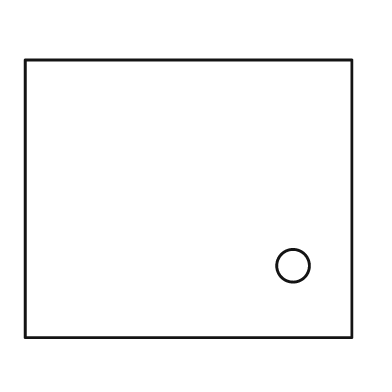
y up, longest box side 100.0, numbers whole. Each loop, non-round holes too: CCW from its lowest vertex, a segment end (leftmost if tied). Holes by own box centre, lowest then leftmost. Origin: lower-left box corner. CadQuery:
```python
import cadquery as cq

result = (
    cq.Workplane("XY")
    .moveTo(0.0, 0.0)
    .lineTo(100.0, 0.0)
    .lineTo(100.0, 85.0)
    .lineTo(0.0, 85.0)
    .close()
    .moveTo(82.0, 22.0)
    .circle(5.0)
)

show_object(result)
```